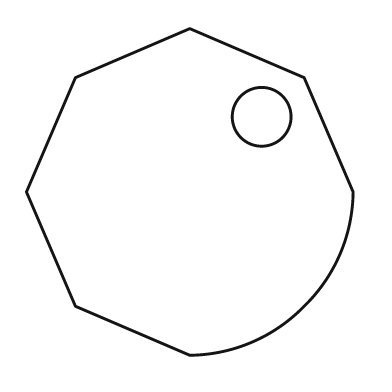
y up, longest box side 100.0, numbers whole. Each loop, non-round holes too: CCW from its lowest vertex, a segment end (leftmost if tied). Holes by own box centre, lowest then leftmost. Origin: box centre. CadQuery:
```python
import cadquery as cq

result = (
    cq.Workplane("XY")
    .moveTo(0.0, -50.0)
    .threePointArc((19.0, -46.0), (35.0, -35.0))
    .threePointArc((46.0, -19.0), (50.0, 0.0))
    .lineTo(35.0, 35.0)
    .lineTo(0.0, 50.0)
    .lineTo(-35.0, 35.0)
    .lineTo(-50.0, 0.0)
    .lineTo(-35.0, -35.0)
    .close()
    .moveTo(22.0, 23.0)
    .circle(9.0)
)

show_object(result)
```